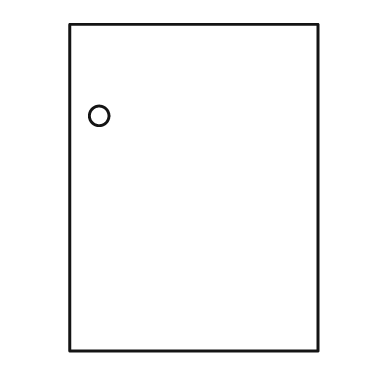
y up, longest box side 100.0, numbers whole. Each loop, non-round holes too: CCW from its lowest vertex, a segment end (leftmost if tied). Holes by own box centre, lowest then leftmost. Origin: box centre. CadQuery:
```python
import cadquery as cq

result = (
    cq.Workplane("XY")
    .moveTo(-38.0, -50.0)
    .lineTo(38.0, -50.0)
    .lineTo(38.0, 50.0)
    .lineTo(-38.0, 50.0)
    .close()
    .moveTo(-29.0, 22.0)
    .circle(3.0)
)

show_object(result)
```